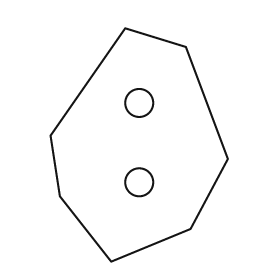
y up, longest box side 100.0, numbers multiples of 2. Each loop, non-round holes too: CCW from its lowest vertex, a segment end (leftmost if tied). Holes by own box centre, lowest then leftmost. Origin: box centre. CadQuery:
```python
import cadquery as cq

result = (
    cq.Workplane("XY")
    .moveTo(-12.0, -50.0)
    .lineTo(22.0, -36.0)
    .lineTo(38.0, -6.0)
    .lineTo(20.0, 42.0)
    .lineTo(-6.0, 50.0)
    .lineTo(-38.0, 4.0)
    .lineTo(-34.0, -22.0)
    .close()
    .moveTo(0.0, -16.0)
    .circle(6.0)
    .moveTo(0.0, 18.0)
    .circle(6.0)
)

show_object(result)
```